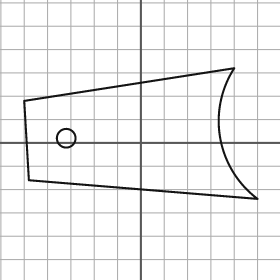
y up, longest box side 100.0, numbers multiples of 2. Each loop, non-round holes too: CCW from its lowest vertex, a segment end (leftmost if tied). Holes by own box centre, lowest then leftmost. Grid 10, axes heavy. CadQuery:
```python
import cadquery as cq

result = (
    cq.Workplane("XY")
    .moveTo(50.0, -24.0)
    .threePointArc((34.0, 2.0), (40.0, 32.0))
    .lineTo(-50.0, 18.0)
    .lineTo(-48.0, -16.0)
    .close()
    .moveTo(-32.0, 2.0)
    .circle(4.0)
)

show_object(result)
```